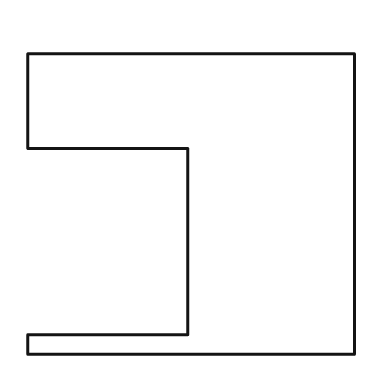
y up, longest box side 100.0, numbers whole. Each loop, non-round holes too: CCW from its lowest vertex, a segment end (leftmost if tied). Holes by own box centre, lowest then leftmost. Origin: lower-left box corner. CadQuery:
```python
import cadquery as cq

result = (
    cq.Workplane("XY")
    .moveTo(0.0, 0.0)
    .lineTo(100.0, 0.0)
    .lineTo(100.0, 92.0)
    .lineTo(0.0, 92.0)
    .lineTo(0.0, 63.0)
    .lineTo(49.0, 63.0)
    .lineTo(49.0, 6.0)
    .lineTo(0.0, 6.0)
    .close()
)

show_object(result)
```